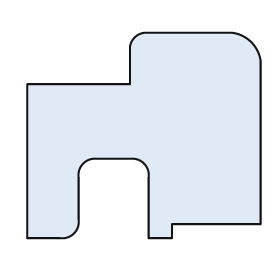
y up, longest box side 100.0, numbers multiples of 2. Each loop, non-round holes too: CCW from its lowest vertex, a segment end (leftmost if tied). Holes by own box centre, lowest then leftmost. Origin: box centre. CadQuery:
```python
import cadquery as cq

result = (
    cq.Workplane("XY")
    .moveTo(-50.0, -44.0)
    .lineTo(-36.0, -44.0)
    .threePointArc((-30.0, -42.0), (-28.0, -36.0))
    .lineTo(-28.0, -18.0)
    .threePointArc((-26.0, -12.0), (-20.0, -10.0))
    .lineTo(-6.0, -10.0)
    .threePointArc((0.0, -12.0), (2.0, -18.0))
    .lineTo(2.0, -44.0)
    .lineTo(12.0, -44.0)
    .lineTo(12.0, -38.0)
    .lineTo(50.0, -38.0)
    .lineTo(50.0, 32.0)
    .threePointArc((46.0, 40.0), (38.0, 44.0))
    .lineTo(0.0, 44.0)
    .threePointArc((-4.0, 42.0), (-6.0, 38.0))
    .lineTo(-6.0, 22.0)
    .lineTo(-50.0, 22.0)
    .close()
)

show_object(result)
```